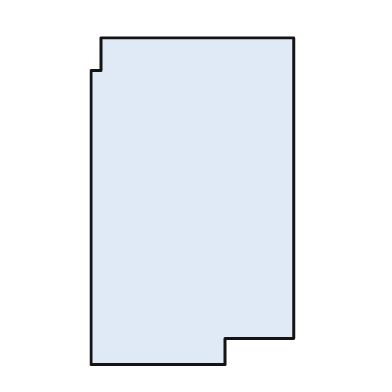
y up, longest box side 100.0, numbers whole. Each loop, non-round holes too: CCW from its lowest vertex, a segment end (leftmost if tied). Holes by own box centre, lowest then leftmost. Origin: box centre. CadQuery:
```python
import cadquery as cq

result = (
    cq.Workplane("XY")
    .moveTo(-31.0, -50.0)
    .lineTo(10.0, -50.0)
    .lineTo(10.0, -42.0)
    .lineTo(31.0, -42.0)
    .lineTo(31.0, 50.0)
    .lineTo(-28.0, 50.0)
    .lineTo(-28.0, 40.0)
    .lineTo(-31.0, 40.0)
    .close()
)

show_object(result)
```